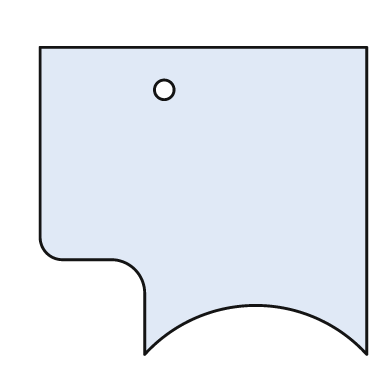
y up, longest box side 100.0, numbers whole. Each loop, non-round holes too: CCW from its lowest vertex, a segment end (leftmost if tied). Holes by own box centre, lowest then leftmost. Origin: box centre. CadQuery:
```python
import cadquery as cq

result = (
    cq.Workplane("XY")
    .moveTo(-18.0, -47.0)
    .threePointArc((16.0, -32.0), (50.0, -47.0))
    .lineTo(50.0, 47.0)
    .lineTo(-50.0, 47.0)
    .lineTo(-50.0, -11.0)
    .threePointArc((-48.0, -16.0), (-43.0, -18.0))
    .lineTo(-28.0, -18.0)
    .threePointArc((-21.0, -21.0), (-18.0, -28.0))
    .close()
    .moveTo(-12.0, 34.0)
    .circle(3.0)
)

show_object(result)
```